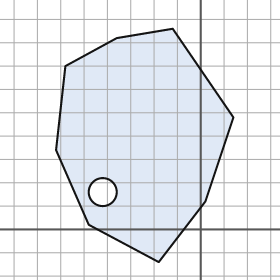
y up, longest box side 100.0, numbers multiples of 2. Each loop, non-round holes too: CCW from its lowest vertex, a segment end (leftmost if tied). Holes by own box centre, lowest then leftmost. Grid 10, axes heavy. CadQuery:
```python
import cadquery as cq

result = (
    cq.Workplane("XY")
    .moveTo(-18.0, -14.0)
    .lineTo(2.0, 12.0)
    .lineTo(14.0, 48.0)
    .lineTo(-12.0, 86.0)
    .lineTo(-36.0, 82.0)
    .lineTo(-58.0, 70.0)
    .lineTo(-62.0, 34.0)
    .lineTo(-48.0, 2.0)
    .close()
    .moveTo(-42.0, 16.0)
    .circle(6.0)
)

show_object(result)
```